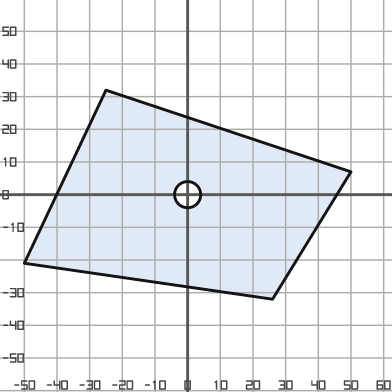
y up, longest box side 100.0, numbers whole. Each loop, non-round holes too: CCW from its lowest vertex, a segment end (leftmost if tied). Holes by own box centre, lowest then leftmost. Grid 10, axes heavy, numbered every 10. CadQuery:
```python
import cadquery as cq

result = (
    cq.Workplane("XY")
    .moveTo(26.0, -32.0)
    .lineTo(50.0, 7.0)
    .lineTo(-25.0, 32.0)
    .lineTo(-50.0, -21.0)
    .close()
    .moveTo(0.0, 0.0)
    .circle(4.0)
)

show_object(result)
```